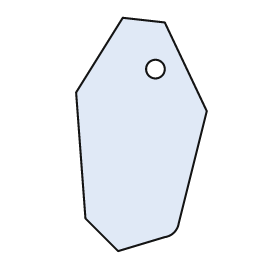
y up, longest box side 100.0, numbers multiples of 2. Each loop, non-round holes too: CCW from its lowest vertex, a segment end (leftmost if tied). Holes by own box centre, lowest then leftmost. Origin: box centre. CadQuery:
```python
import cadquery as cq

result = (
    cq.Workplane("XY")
    .moveTo(-10.0, -50.0)
    .lineTo(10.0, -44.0)
    .threePointArc((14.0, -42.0), (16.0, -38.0))
    .lineTo(28.0, 10.0)
    .lineTo(10.0, 48.0)
    .lineTo(-8.0, 50.0)
    .lineTo(-28.0, 18.0)
    .lineTo(-24.0, -36.0)
    .close()
    .moveTo(6.0, 28.0)
    .circle(4.0)
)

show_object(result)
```